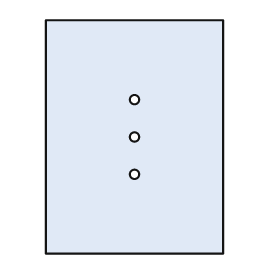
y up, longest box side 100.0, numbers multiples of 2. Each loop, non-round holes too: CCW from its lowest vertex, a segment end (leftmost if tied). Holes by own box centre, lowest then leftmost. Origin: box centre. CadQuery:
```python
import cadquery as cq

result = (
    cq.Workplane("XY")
    .moveTo(-38.0, -50.0)
    .lineTo(38.0, -50.0)
    .lineTo(38.0, 50.0)
    .lineTo(-38.0, 50.0)
    .close()
    .moveTo(0.0, -16.0)
    .circle(2.0)
    .moveTo(0.0, 0.0)
    .circle(2.0)
    .moveTo(0.0, 16.0)
    .circle(2.0)
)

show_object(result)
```